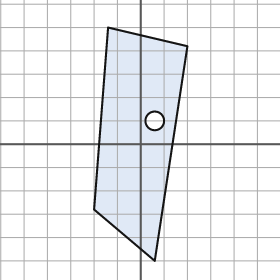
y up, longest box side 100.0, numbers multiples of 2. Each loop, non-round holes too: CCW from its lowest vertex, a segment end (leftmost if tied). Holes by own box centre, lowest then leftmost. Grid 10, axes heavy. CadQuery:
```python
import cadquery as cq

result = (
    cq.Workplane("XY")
    .moveTo(6.0, -50.0)
    .lineTo(20.0, 42.0)
    .lineTo(-14.0, 50.0)
    .lineTo(-20.0, -28.0)
    .close()
    .moveTo(6.0, 10.0)
    .circle(4.0)
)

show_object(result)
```